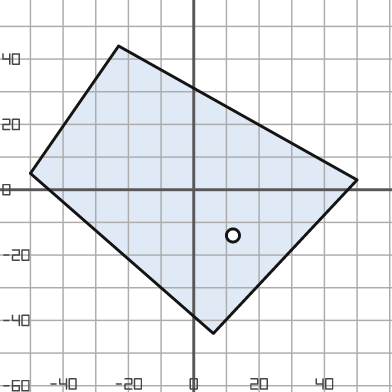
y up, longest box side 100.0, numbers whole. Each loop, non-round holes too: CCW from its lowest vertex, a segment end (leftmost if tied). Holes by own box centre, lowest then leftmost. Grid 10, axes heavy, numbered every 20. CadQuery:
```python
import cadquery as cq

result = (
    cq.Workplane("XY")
    .moveTo(6.0, -44.0)
    .lineTo(50.0, 3.0)
    .lineTo(-23.0, 44.0)
    .lineTo(-50.0, 5.0)
    .close()
    .moveTo(12.0, -14.0)
    .circle(2.0)
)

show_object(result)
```